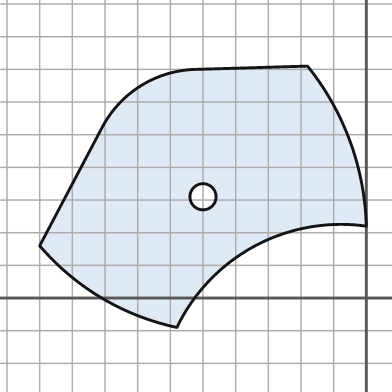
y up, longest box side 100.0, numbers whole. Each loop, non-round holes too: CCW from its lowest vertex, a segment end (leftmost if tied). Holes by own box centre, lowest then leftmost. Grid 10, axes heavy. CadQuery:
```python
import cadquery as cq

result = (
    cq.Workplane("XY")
    .moveTo(-58.0, -9.0)
    .threePointArc((-34.0, 16.0), (0.0, 22.0))
    .threePointArc((-5.0, 48.0), (-18.0, 71.0))
    .lineTo(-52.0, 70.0)
    .threePointArc((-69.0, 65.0), (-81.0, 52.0))
    .lineTo(-100.0, 16.0)
    .threePointArc((-81.0, 0.0), (-58.0, -9.0))
    .close()
    .moveTo(-50.0, 31.0)
    .circle(4.0)
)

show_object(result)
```